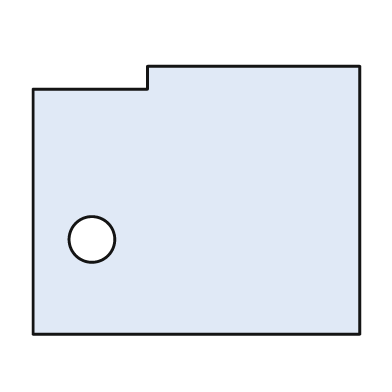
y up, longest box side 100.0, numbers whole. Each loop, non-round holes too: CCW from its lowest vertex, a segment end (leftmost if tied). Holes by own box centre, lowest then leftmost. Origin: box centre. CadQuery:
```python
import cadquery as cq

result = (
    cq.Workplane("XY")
    .moveTo(-50.0, -41.0)
    .lineTo(50.0, -41.0)
    .lineTo(50.0, 41.0)
    .lineTo(-15.0, 41.0)
    .lineTo(-15.0, 34.0)
    .lineTo(-50.0, 34.0)
    .close()
    .moveTo(-32.0, -12.0)
    .circle(7.0)
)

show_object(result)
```